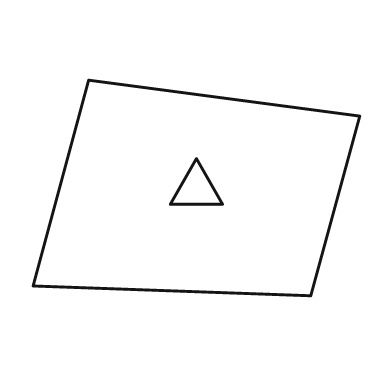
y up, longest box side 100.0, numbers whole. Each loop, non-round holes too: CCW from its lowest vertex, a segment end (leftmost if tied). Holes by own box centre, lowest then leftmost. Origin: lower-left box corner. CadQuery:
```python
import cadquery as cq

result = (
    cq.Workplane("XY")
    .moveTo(85.0, 0.0)
    .lineTo(100.0, 55.0)
    .lineTo(17.0, 66.0)
    .lineTo(0.0, 3.0)
    .close()
    .moveTo(42.0, 28.0)
    .lineTo(58.0, 28.0)
    .lineTo(50.0, 42.0)
    .close()
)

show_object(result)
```